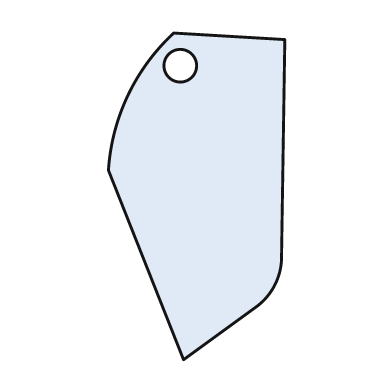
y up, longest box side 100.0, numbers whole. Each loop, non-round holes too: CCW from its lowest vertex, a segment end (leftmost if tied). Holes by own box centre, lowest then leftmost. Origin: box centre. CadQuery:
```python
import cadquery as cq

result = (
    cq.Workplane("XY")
    .moveTo(-4.0, -50.0)
    .lineTo(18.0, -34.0)
    .threePointArc((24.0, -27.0), (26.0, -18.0))
    .lineTo(27.0, 48.0)
    .lineTo(-7.0, 50.0)
    .threePointArc((-21.0, 31.0), (-27.0, 8.0))
    .close()
    .moveTo(-5.0, 40.0)
    .circle(5.0)
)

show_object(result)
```